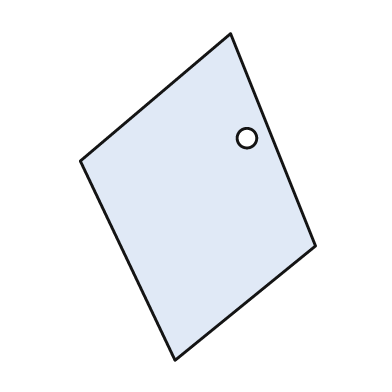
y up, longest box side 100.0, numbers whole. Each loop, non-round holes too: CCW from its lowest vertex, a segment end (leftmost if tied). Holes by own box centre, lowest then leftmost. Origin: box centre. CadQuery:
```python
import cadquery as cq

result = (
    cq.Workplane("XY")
    .moveTo(-7.0, -50.0)
    .lineTo(36.0, -15.0)
    .lineTo(10.0, 50.0)
    .lineTo(-36.0, 11.0)
    .close()
    .moveTo(15.0, 18.0)
    .circle(3.0)
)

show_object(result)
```